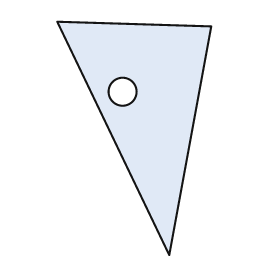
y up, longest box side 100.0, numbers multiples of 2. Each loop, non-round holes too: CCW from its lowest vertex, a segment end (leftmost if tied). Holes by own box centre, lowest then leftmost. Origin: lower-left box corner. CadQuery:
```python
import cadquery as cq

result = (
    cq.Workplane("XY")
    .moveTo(48.0, 0.0)
    .lineTo(66.0, 98.0)
    .lineTo(0.0, 100.0)
    .close()
    .moveTo(28.0, 70.0)
    .circle(6.0)
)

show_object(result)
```